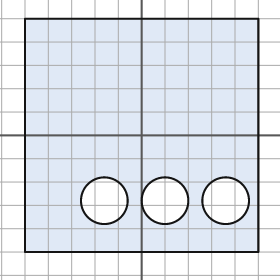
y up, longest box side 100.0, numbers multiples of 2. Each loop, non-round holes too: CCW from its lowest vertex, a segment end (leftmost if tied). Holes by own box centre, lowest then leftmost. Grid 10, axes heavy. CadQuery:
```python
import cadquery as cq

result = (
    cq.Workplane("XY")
    .moveTo(-50.0, -50.0)
    .lineTo(50.0, -50.0)
    .lineTo(50.0, 50.0)
    .lineTo(-50.0, 50.0)
    .close()
    .moveTo(-16.0, -28.0)
    .circle(10.0)
    .moveTo(10.0, -28.0)
    .circle(10.0)
    .moveTo(36.0, -28.0)
    .circle(10.0)
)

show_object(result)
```